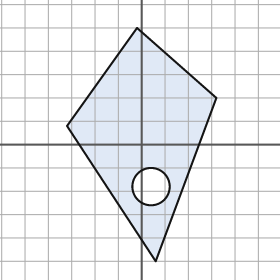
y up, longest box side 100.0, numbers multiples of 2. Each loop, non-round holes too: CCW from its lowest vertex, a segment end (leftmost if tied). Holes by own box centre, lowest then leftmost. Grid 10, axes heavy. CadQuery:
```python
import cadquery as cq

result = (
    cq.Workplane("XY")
    .moveTo(6.0, -50.0)
    .lineTo(32.0, 20.0)
    .lineTo(-2.0, 50.0)
    .lineTo(-32.0, 8.0)
    .close()
    .moveTo(4.0, -18.0)
    .circle(8.0)
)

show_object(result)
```